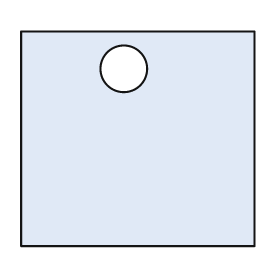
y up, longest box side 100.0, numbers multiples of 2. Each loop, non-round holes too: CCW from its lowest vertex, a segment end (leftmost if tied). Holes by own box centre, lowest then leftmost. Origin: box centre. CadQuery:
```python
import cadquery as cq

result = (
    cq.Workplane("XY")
    .moveTo(-50.0, -46.0)
    .lineTo(50.0, -46.0)
    .lineTo(50.0, 46.0)
    .lineTo(-50.0, 46.0)
    .close()
    .moveTo(-6.0, 30.0)
    .circle(10.0)
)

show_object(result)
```